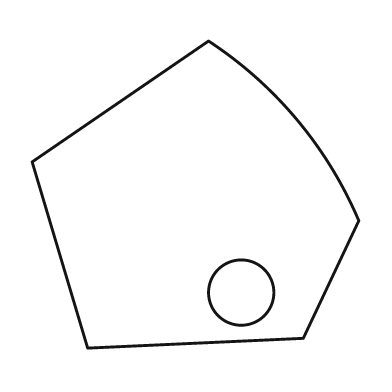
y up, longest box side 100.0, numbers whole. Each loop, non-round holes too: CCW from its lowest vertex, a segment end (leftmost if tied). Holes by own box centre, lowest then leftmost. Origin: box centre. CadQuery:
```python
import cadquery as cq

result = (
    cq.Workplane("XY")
    .moveTo(-33.0, -47.0)
    .lineTo(33.0, -44.0)
    .lineTo(50.0, -8.0)
    .threePointArc((31.0, 23.0), (4.0, 47.0))
    .lineTo(-50.0, 10.0)
    .close()
    .moveTo(14.0, -30.0)
    .circle(10.0)
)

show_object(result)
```